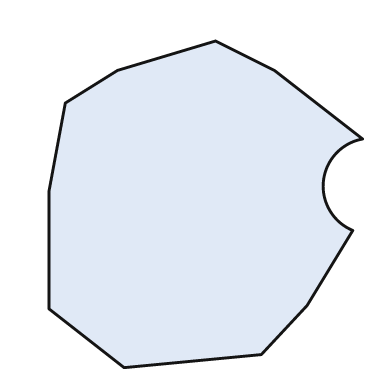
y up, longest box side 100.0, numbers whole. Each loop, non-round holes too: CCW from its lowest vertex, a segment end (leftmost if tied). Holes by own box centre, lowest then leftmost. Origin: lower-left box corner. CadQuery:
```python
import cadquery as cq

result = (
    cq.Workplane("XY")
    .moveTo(23.0, 0.0)
    .lineTo(65.0, 4.0)
    .lineTo(79.0, 19.0)
    .lineTo(93.0, 42.0)
    .threePointArc((84.0, 57.0), (96.0, 70.0))
    .lineTo(69.0, 91.0)
    .lineTo(51.0, 100.0)
    .lineTo(21.0, 91.0)
    .lineTo(5.0, 81.0)
    .lineTo(0.0, 54.0)
    .lineTo(0.0, 18.0)
    .close()
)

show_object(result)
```